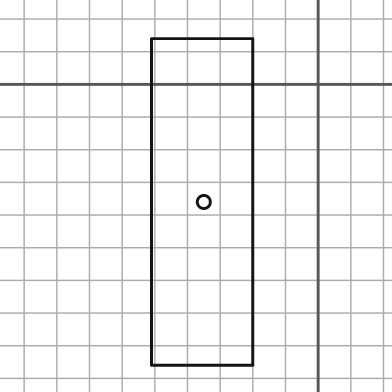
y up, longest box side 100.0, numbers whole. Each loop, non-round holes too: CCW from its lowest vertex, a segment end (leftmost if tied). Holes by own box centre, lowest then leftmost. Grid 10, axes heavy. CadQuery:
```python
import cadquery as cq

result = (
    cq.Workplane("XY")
    .moveTo(-51.0, -86.0)
    .lineTo(-20.0, -86.0)
    .lineTo(-20.0, 14.0)
    .lineTo(-51.0, 14.0)
    .close()
    .moveTo(-35.0, -36.0)
    .circle(2.0)
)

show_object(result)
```